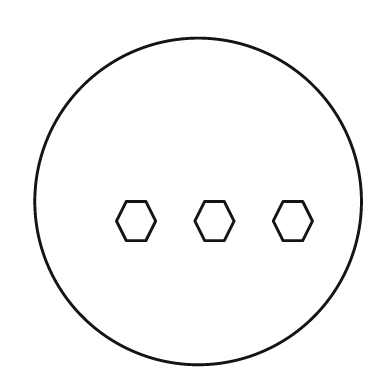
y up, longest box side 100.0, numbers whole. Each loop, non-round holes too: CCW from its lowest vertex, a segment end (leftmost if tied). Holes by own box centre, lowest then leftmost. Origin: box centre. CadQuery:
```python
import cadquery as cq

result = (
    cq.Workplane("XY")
    .moveTo(0.0, 0.0)
    .circle(50.0)
    .moveTo(-22.0, -12.0)
    .lineTo(-16.0, -12.0)
    .lineTo(-13.0, -6.0)
    .lineTo(-16.0, 0.0)
    .lineTo(-22.0, 0.0)
    .lineTo(-25.0, -6.0)
    .close()
    .moveTo(2.0, -12.0)
    .lineTo(8.0, -12.0)
    .lineTo(11.0, -6.0)
    .lineTo(8.0, 0.0)
    .lineTo(2.0, 0.0)
    .lineTo(-1.0, -6.0)
    .close()
    .moveTo(26.0, -12.0)
    .lineTo(32.0, -12.0)
    .lineTo(35.0, -6.0)
    .lineTo(32.0, 0.0)
    .lineTo(26.0, 0.0)
    .lineTo(23.0, -6.0)
    .close()
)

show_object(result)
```